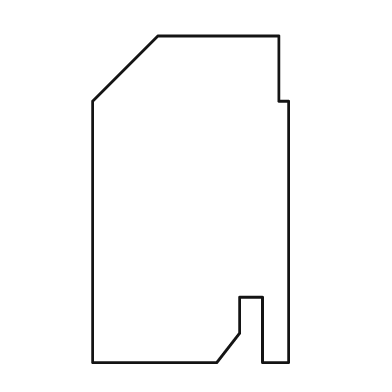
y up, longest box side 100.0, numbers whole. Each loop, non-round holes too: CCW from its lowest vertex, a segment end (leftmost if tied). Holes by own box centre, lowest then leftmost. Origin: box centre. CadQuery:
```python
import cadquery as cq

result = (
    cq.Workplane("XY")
    .moveTo(-30.0, -50.0)
    .lineTo(8.0, -50.0)
    .lineTo(15.0, -41.0)
    .lineTo(15.0, -30.0)
    .lineTo(22.0, -30.0)
    .lineTo(22.0, -50.0)
    .lineTo(30.0, -50.0)
    .lineTo(30.0, 30.0)
    .lineTo(27.0, 30.0)
    .lineTo(27.0, 50.0)
    .lineTo(-10.0, 50.0)
    .lineTo(-30.0, 30.0)
    .close()
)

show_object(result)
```